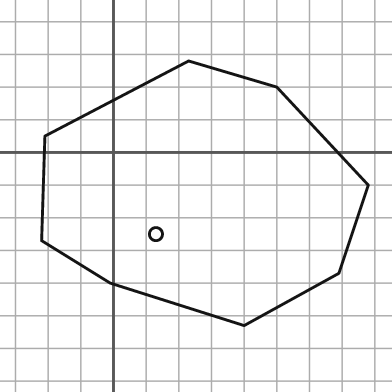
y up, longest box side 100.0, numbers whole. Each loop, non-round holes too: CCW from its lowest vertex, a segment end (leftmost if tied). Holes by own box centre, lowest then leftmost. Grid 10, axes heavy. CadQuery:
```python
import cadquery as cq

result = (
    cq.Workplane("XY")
    .moveTo(40.0, -53.0)
    .lineTo(69.0, -37.0)
    .lineTo(78.0, -10.0)
    .lineTo(50.0, 20.0)
    .lineTo(23.0, 28.0)
    .lineTo(-21.0, 5.0)
    .lineTo(-22.0, -27.0)
    .lineTo(-1.0, -40.0)
    .close()
    .moveTo(13.0, -25.0)
    .circle(2.0)
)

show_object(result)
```